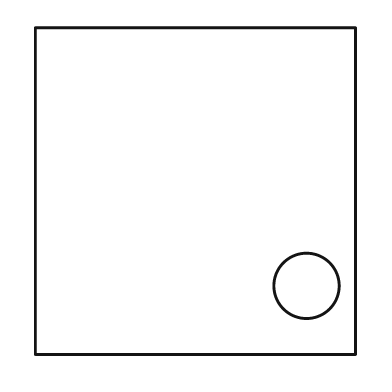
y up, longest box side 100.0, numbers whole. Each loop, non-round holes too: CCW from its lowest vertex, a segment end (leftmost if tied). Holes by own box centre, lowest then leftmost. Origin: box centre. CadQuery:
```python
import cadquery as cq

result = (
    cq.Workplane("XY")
    .moveTo(-49.0, -50.0)
    .lineTo(49.0, -50.0)
    .lineTo(49.0, 50.0)
    .lineTo(-49.0, 50.0)
    .close()
    .moveTo(34.0, -29.0)
    .circle(10.0)
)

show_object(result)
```